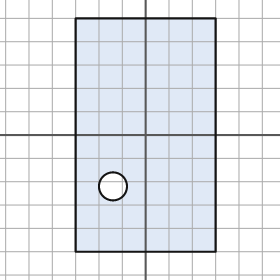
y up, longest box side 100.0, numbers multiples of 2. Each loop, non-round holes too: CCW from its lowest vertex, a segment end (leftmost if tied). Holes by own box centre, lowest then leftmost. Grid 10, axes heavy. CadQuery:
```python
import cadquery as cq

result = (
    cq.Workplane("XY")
    .moveTo(-30.0, -50.0)
    .lineTo(30.0, -50.0)
    .lineTo(30.0, 50.0)
    .lineTo(-30.0, 50.0)
    .close()
    .moveTo(-14.0, -22.0)
    .circle(6.0)
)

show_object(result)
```